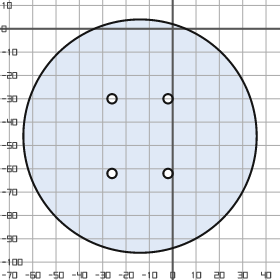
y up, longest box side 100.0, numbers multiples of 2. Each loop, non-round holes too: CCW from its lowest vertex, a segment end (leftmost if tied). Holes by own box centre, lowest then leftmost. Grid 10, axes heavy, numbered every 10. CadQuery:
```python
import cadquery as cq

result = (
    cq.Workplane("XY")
    .moveTo(-14.0, -46.0)
    .circle(50.0)
    .moveTo(-26.0, -62.0)
    .circle(2.0)
    .moveTo(-2.0, -62.0)
    .circle(2.0)
    .moveTo(-26.0, -30.0)
    .circle(2.0)
    .moveTo(-2.0, -30.0)
    .circle(2.0)
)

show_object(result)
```